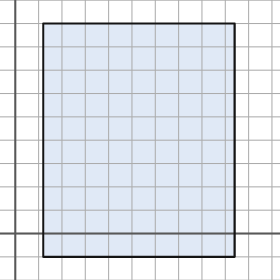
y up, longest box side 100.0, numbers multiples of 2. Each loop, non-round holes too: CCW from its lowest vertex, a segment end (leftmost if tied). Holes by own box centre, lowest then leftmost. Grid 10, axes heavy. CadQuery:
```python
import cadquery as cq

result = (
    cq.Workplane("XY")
    .moveTo(12.0, -10.0)
    .lineTo(94.0, -10.0)
    .lineTo(94.0, 90.0)
    .lineTo(12.0, 90.0)
    .close()
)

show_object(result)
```